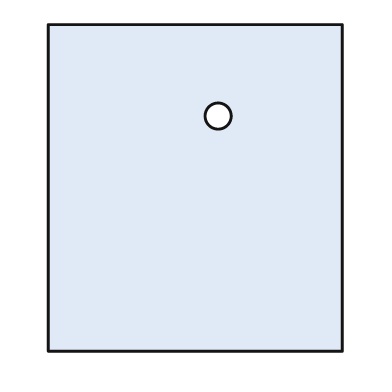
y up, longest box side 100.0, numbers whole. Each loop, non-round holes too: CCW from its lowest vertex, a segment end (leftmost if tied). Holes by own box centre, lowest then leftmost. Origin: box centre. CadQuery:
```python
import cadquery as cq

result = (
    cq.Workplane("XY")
    .moveTo(-45.0, -50.0)
    .lineTo(45.0, -50.0)
    .lineTo(45.0, 50.0)
    .lineTo(-45.0, 50.0)
    .close()
    .moveTo(7.0, 22.0)
    .circle(4.0)
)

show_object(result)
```